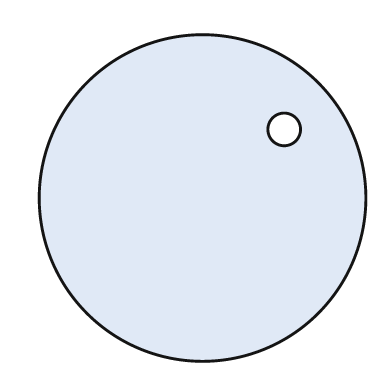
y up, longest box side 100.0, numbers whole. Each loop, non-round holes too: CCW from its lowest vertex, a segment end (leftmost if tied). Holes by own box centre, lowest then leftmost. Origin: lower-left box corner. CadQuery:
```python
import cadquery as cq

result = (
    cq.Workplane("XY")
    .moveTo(50.0, 50.0)
    .circle(50.0)
    .moveTo(75.0, 71.0)
    .circle(5.0)
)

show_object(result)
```